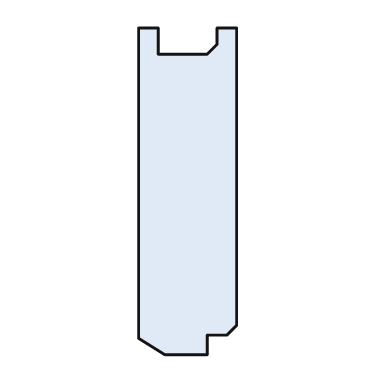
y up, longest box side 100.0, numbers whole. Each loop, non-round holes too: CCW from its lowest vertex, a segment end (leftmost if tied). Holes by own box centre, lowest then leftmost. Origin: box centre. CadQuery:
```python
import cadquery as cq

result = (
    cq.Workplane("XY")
    .moveTo(-7.0, -50.0)
    .lineTo(6.0, -50.0)
    .lineTo(6.0, -44.0)
    .lineTo(12.0, -44.0)
    .lineTo(15.0, -41.0)
    .lineTo(15.0, 50.0)
    .lineTo(9.0, 50.0)
    .lineTo(9.0, 45.0)
    .lineTo(6.0, 42.0)
    .lineTo(-9.0, 42.0)
    .lineTo(-9.0, 50.0)
    .lineTo(-15.0, 50.0)
    .lineTo(-15.0, -45.0)
    .close()
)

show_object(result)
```